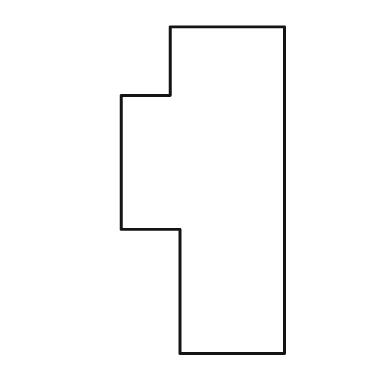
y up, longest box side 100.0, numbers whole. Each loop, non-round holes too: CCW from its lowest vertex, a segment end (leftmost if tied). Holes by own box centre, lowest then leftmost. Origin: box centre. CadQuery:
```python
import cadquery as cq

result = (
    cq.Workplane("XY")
    .moveTo(-7.0, -50.0)
    .lineTo(25.0, -50.0)
    .lineTo(25.0, 50.0)
    .lineTo(-10.0, 50.0)
    .lineTo(-10.0, 29.0)
    .lineTo(-25.0, 29.0)
    .lineTo(-25.0, -12.0)
    .lineTo(-7.0, -12.0)
    .close()
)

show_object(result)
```